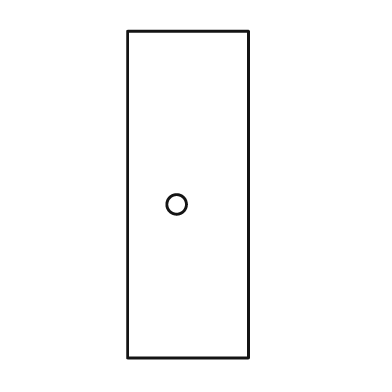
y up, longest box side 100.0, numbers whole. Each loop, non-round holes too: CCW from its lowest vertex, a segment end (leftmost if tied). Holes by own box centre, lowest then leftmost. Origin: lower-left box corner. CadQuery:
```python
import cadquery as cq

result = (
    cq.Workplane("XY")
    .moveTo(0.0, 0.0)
    .lineTo(37.0, 0.0)
    .lineTo(37.0, 100.0)
    .lineTo(0.0, 100.0)
    .close()
    .moveTo(15.0, 47.0)
    .circle(3.0)
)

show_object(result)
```